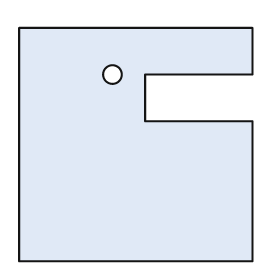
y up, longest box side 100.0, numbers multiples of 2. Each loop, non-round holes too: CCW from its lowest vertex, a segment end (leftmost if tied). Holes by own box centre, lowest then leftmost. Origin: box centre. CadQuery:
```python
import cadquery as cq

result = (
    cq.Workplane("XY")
    .moveTo(-50.0, -50.0)
    .lineTo(50.0, -50.0)
    .lineTo(50.0, 10.0)
    .lineTo(4.0, 10.0)
    .lineTo(4.0, 30.0)
    .lineTo(50.0, 30.0)
    .lineTo(50.0, 50.0)
    .lineTo(-50.0, 50.0)
    .close()
    .moveTo(-10.0, 30.0)
    .circle(4.0)
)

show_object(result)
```